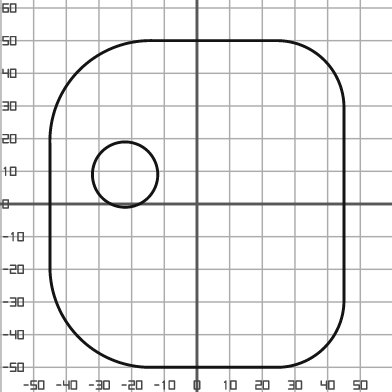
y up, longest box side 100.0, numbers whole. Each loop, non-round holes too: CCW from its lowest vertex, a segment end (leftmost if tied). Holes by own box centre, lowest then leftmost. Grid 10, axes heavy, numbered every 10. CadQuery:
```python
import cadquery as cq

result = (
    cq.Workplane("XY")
    .moveTo(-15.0, -50.0)
    .lineTo(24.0, -50.0)
    .threePointArc((39.0, -44.0), (45.0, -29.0))
    .lineTo(45.0, 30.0)
    .threePointArc((39.0, 44.0), (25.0, 50.0))
    .lineTo(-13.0, 50.0)
    .threePointArc((-36.0, 41.0), (-45.0, 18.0))
    .lineTo(-45.0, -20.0)
    .threePointArc((-36.0, -41.0), (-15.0, -50.0))
    .close()
    .moveTo(-22.0, 9.0)
    .circle(10.0)
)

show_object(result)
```